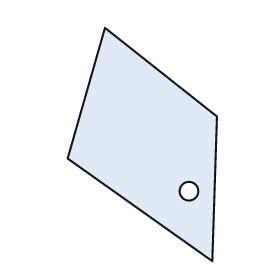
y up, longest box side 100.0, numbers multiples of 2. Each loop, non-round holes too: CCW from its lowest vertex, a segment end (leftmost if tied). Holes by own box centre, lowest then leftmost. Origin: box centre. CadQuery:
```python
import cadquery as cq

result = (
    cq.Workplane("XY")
    .moveTo(30.0, -50.0)
    .lineTo(32.0, 12.0)
    .lineTo(-16.0, 50.0)
    .lineTo(-32.0, -6.0)
    .close()
    .moveTo(20.0, -20.0)
    .circle(4.0)
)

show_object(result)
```